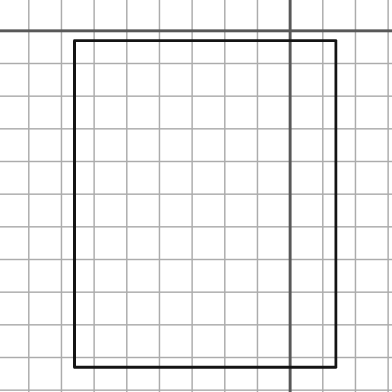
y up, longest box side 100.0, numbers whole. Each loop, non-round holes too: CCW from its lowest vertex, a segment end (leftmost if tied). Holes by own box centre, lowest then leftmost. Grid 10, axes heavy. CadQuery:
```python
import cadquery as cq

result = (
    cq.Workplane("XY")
    .moveTo(-66.0, -103.0)
    .lineTo(14.0, -103.0)
    .lineTo(14.0, -3.0)
    .lineTo(-66.0, -3.0)
    .close()
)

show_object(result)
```